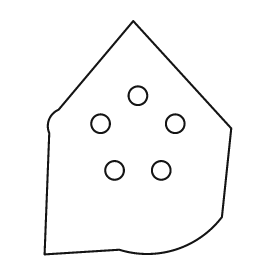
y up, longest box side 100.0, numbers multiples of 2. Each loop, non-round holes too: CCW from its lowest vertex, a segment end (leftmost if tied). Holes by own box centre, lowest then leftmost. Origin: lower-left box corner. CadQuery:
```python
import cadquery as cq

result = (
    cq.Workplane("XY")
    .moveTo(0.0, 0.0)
    .lineTo(32.0, 2.0)
    .threePointArc((56.0, 2.0), (76.0, 16.0))
    .lineTo(80.0, 54.0)
    .lineTo(38.0, 100.0)
    .lineTo(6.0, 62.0)
    .threePointArc((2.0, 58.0), (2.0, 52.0))
    .close()
    .moveTo(30.0, 36.0)
    .circle(4.0)
    .moveTo(50.0, 36.0)
    .circle(4.0)
    .moveTo(24.0, 56.0)
    .circle(4.0)
    .moveTo(56.0, 56.0)
    .circle(4.0)
    .moveTo(40.0, 68.0)
    .circle(4.0)
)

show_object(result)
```